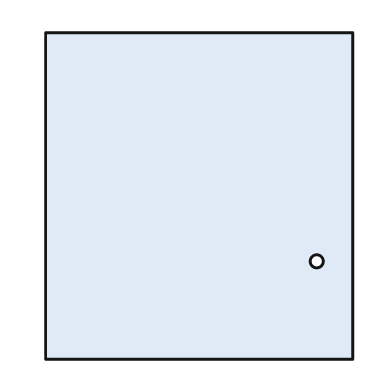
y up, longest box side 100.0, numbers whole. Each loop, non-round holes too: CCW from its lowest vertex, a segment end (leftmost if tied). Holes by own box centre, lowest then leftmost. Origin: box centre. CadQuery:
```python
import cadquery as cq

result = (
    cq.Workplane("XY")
    .moveTo(-47.0, -50.0)
    .lineTo(47.0, -50.0)
    .lineTo(47.0, 50.0)
    .lineTo(-47.0, 50.0)
    .close()
    .moveTo(36.0, -20.0)
    .circle(2.0)
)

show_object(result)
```